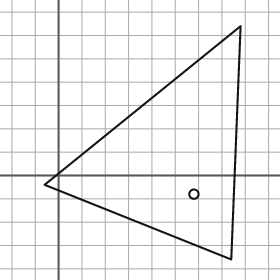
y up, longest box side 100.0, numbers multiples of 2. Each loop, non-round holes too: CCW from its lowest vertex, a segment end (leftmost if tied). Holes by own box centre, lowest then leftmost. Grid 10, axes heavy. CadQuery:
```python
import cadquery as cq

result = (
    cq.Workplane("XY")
    .moveTo(74.0, -36.0)
    .lineTo(78.0, 64.0)
    .lineTo(-6.0, -4.0)
    .close()
    .moveTo(58.0, -8.0)
    .circle(2.0)
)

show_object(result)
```